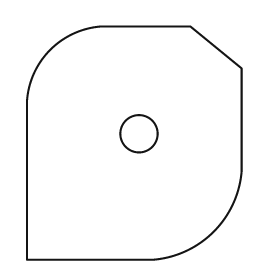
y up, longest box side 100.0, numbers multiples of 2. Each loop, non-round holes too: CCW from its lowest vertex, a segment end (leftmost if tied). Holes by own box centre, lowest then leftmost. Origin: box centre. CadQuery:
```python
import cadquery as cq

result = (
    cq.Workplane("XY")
    .moveTo(-46.0, -50.0)
    .lineTo(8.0, -50.0)
    .threePointArc((34.0, -38.0), (46.0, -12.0))
    .lineTo(46.0, 32.0)
    .lineTo(24.0, 50.0)
    .lineTo(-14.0, 50.0)
    .threePointArc((-36.0, 40.0), (-46.0, 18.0))
    .close()
    .moveTo(2.0, 4.0)
    .circle(8.0)
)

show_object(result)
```